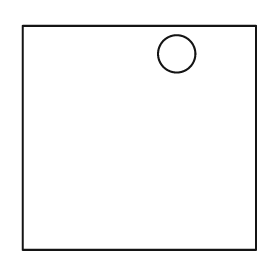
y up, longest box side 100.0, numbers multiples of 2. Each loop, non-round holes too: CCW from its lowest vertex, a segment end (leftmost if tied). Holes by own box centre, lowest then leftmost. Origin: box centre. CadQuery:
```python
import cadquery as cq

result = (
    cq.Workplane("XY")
    .moveTo(-50.0, -48.0)
    .lineTo(50.0, -48.0)
    .lineTo(50.0, 48.0)
    .lineTo(-50.0, 48.0)
    .close()
    .moveTo(16.0, 36.0)
    .circle(8.0)
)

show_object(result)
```